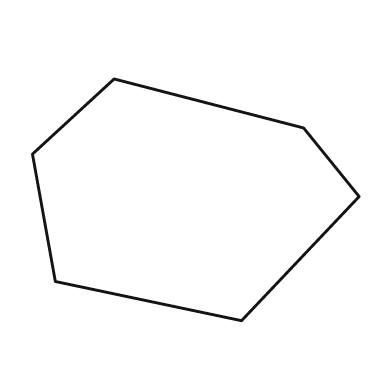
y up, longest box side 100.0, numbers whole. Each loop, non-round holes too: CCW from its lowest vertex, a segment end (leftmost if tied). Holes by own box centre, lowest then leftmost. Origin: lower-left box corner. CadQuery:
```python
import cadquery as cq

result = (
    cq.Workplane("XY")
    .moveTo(64.0, 0.0)
    .lineTo(100.0, 38.0)
    .lineTo(83.0, 59.0)
    .lineTo(25.0, 74.0)
    .lineTo(0.0, 51.0)
    .lineTo(7.0, 12.0)
    .close()
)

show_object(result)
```